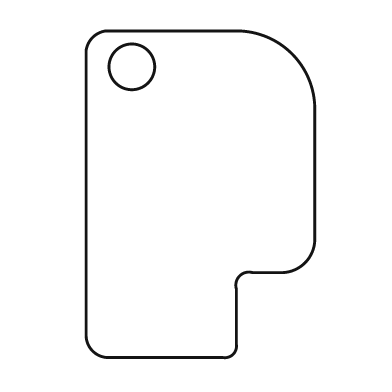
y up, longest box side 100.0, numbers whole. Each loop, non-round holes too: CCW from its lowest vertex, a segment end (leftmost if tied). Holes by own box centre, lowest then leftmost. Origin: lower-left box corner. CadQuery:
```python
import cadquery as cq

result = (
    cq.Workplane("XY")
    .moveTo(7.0, 0.0)
    .lineTo(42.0, 0.0)
    .threePointArc((45.0, 1.0), (46.0, 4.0))
    .lineTo(46.0, 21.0)
    .threePointArc((47.0, 25.0), (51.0, 26.0))
    .lineTo(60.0, 26.0)
    .threePointArc((67.0, 29.0), (70.0, 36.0))
    .lineTo(70.0, 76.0)
    .threePointArc((63.0, 93.0), (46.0, 100.0))
    .lineTo(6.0, 100.0)
    .threePointArc((2.0, 98.0), (0.0, 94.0))
    .lineTo(0.0, 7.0)
    .threePointArc((2.0, 2.0), (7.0, 0.0))
    .close()
    .moveTo(14.0, 89.0)
    .circle(7.0)
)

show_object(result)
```